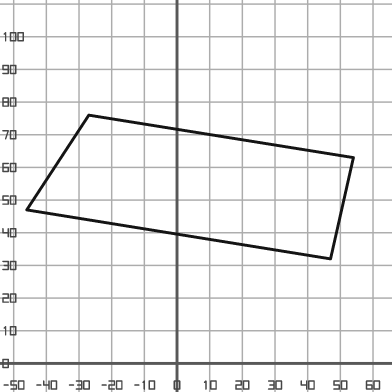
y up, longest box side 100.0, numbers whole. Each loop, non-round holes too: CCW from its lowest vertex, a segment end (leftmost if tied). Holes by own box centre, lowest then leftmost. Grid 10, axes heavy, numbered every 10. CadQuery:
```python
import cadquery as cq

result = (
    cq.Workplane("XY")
    .moveTo(47.0, 32.0)
    .lineTo(54.0, 63.0)
    .lineTo(-27.0, 76.0)
    .lineTo(-46.0, 47.0)
    .close()
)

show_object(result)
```